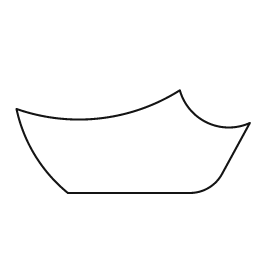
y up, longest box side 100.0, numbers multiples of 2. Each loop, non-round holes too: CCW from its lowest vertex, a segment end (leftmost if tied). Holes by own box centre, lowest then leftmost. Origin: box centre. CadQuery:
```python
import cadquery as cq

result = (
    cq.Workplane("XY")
    .moveTo(-28.0, -22.0)
    .lineTo(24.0, -22.0)
    .threePointArc((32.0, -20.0), (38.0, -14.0))
    .lineTo(50.0, 8.0)
    .threePointArc((32.0, 8.0), (20.0, 22.0))
    .threePointArc((-14.0, 10.0), (-50.0, 14.0))
    .threePointArc((-42.0, -6.0), (-28.0, -22.0))
    .close()
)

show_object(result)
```